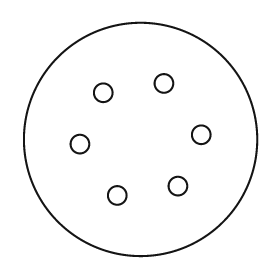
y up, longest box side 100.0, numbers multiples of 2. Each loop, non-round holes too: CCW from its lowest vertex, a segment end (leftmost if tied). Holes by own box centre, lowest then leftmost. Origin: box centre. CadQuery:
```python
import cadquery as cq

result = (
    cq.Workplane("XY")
    .moveTo(0.0, 0.0)
    .circle(50.0)
    .moveTo(-10.0, -24.0)
    .circle(4.0)
    .moveTo(16.0, -20.0)
    .circle(4.0)
    .moveTo(-26.0, -2.0)
    .circle(4.0)
    .moveTo(26.0, 2.0)
    .circle(4.0)
    .moveTo(-16.0, 20.0)
    .circle(4.0)
    .moveTo(10.0, 24.0)
    .circle(4.0)
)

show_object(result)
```